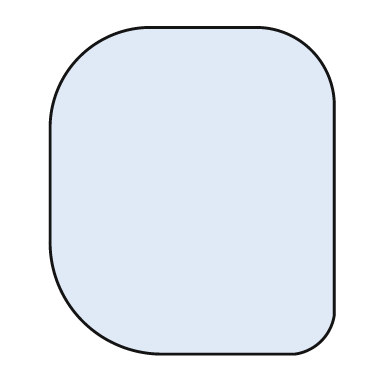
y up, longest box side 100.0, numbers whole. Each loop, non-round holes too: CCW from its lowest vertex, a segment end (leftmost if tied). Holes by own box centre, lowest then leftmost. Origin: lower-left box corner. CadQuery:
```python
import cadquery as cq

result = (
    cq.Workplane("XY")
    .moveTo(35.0, 0.0)
    .lineTo(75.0, 0.0)
    .threePointArc((83.0, 4.0), (87.0, 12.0))
    .lineTo(87.0, 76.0)
    .threePointArc((80.0, 93.0), (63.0, 100.0))
    .lineTo(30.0, 100.0)
    .threePointArc((9.0, 91.0), (0.0, 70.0))
    .lineTo(0.0, 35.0)
    .threePointArc((10.0, 10.0), (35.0, 0.0))
    .close()
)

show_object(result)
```